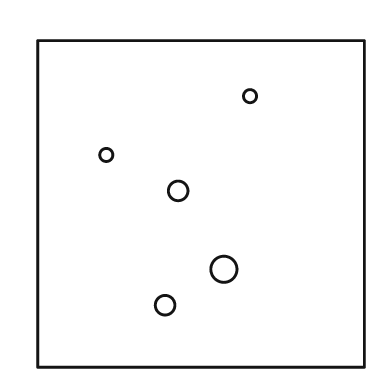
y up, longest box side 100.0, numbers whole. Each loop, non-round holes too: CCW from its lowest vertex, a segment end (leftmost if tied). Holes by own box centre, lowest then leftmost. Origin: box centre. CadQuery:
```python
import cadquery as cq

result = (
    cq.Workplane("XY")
    .moveTo(-50.0, -50.0)
    .lineTo(50.0, -50.0)
    .lineTo(50.0, 50.0)
    .lineTo(-50.0, 50.0)
    .close()
    .moveTo(-11.0, -31.0)
    .circle(3.0)
    .moveTo(7.0, -20.0)
    .circle(4.0)
    .moveTo(-7.0, 4.0)
    .circle(3.0)
    .moveTo(-29.0, 15.0)
    .circle(2.0)
    .moveTo(15.0, 33.0)
    .circle(2.0)
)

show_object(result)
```